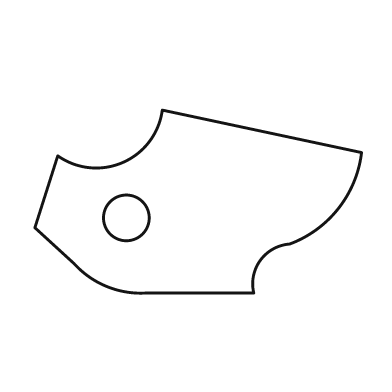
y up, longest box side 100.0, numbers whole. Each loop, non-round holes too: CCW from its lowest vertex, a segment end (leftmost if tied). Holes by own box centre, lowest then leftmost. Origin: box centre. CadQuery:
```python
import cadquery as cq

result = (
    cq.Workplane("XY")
    .moveTo(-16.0, -28.0)
    .lineTo(17.0, -28.0)
    .threePointArc((19.0, -18.0), (28.0, -13.0))
    .threePointArc((43.0, -2.0), (50.0, 15.0))
    .lineTo(-11.0, 28.0)
    .threePointArc((-23.0, 12.0), (-43.0, 14.0))
    .lineTo(-50.0, -8.0)
    .lineTo(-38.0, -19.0)
    .threePointArc((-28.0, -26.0), (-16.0, -28.0))
    .close()
    .moveTo(-22.0, -5.0)
    .circle(7.0)
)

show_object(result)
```